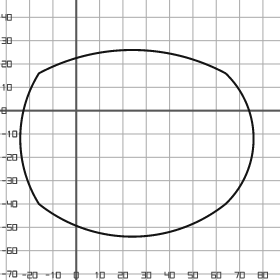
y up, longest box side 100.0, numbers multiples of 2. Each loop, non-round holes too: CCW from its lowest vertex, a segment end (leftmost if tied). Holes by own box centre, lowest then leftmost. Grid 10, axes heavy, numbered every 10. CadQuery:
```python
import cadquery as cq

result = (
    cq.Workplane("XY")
    .moveTo(-16.0, -40.0)
    .threePointArc((24.0, -54.0), (64.0, -40.0))
    .threePointArc((76.0, -12.0), (64.0, 16.0))
    .threePointArc((24.0, 26.0), (-16.0, 16.0))
    .threePointArc((-24.0, -12.0), (-16.0, -40.0))
    .close()
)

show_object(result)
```